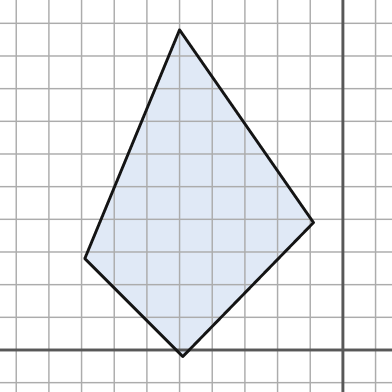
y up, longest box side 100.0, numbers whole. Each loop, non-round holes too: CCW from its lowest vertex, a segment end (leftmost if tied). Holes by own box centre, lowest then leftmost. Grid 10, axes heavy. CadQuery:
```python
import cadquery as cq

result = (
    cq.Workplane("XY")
    .moveTo(-49.0, -2.0)
    .lineTo(-9.0, 39.0)
    .lineTo(-50.0, 98.0)
    .lineTo(-79.0, 28.0)
    .close()
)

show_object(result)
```